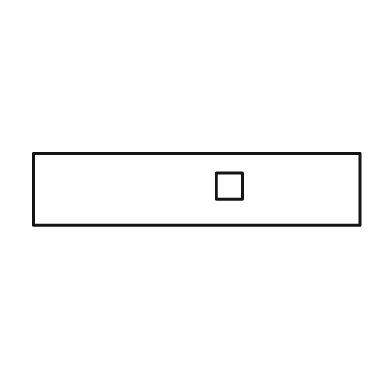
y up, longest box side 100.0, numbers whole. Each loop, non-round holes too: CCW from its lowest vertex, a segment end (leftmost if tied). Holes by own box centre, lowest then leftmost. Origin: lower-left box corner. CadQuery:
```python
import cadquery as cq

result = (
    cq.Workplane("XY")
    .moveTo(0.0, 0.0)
    .lineTo(100.0, 0.0)
    .lineTo(100.0, 22.0)
    .lineTo(0.0, 22.0)
    .close()
    .moveTo(56.0, 8.0)
    .lineTo(64.0, 8.0)
    .lineTo(64.0, 16.0)
    .lineTo(56.0, 16.0)
    .close()
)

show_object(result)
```